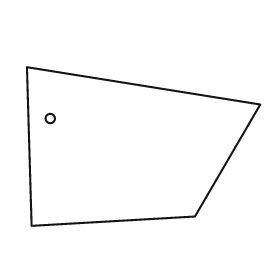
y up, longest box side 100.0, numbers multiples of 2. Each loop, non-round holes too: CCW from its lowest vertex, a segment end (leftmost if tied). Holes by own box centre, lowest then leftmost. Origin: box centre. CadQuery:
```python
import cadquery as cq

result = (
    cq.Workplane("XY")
    .moveTo(-48.0, -34.0)
    .lineTo(22.0, -30.0)
    .lineTo(50.0, 18.0)
    .lineTo(-50.0, 34.0)
    .close()
    .moveTo(-40.0, 12.0)
    .circle(2.0)
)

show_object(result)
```